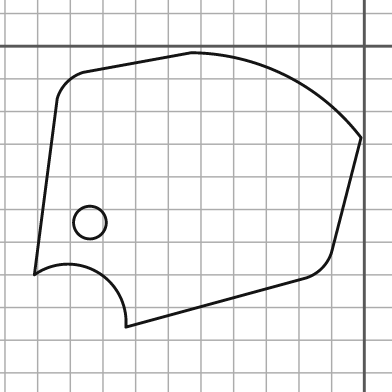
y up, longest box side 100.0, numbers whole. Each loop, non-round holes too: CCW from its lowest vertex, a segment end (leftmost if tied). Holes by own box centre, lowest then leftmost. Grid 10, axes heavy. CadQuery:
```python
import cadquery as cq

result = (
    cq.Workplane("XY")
    .moveTo(-73.0, -86.0)
    .lineTo(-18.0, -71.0)
    .threePointArc((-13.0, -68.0), (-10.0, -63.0))
    .lineTo(-1.0, -28.0)
    .threePointArc((-24.0, -9.0), (-53.0, -2.0))
    .lineTo(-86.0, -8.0)
    .threePointArc((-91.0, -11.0), (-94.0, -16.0))
    .lineTo(-101.0, -70.0)
    .threePointArc((-82.0, -69.0), (-73.0, -86.0))
    .close()
    .moveTo(-84.0, -54.0)
    .circle(5.0)
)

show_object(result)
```